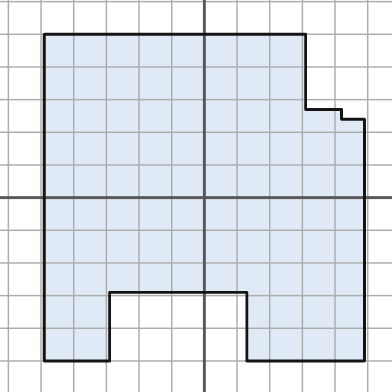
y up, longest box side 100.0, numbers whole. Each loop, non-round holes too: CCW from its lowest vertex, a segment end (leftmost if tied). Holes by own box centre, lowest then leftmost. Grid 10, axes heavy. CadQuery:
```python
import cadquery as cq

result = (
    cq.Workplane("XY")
    .moveTo(-49.0, -50.0)
    .lineTo(-29.0, -50.0)
    .lineTo(-29.0, -29.0)
    .lineTo(13.0, -29.0)
    .lineTo(13.0, -50.0)
    .lineTo(49.0, -50.0)
    .lineTo(49.0, 24.0)
    .lineTo(42.0, 24.0)
    .lineTo(42.0, 27.0)
    .lineTo(31.0, 27.0)
    .lineTo(31.0, 50.0)
    .lineTo(-49.0, 50.0)
    .close()
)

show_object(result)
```